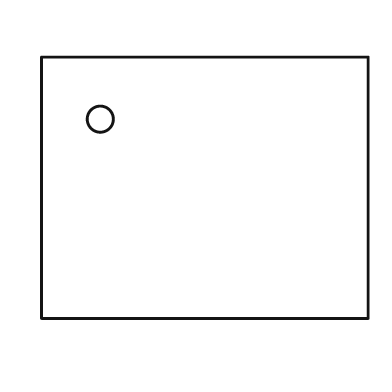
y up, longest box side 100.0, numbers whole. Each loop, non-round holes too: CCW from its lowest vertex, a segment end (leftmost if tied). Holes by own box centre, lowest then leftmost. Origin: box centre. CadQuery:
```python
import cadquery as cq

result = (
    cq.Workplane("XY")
    .moveTo(-50.0, -40.0)
    .lineTo(50.0, -40.0)
    .lineTo(50.0, 40.0)
    .lineTo(-50.0, 40.0)
    .close()
    .moveTo(-32.0, 21.0)
    .circle(4.0)
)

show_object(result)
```